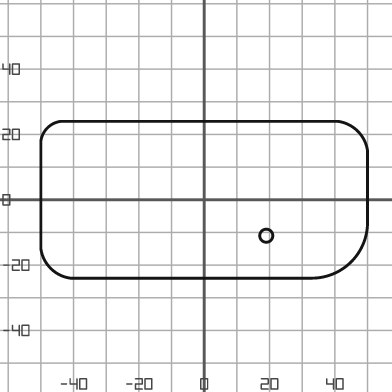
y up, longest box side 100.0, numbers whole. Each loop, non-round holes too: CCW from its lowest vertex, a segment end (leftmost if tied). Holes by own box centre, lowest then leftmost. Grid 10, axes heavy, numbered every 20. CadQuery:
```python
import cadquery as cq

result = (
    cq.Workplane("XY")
    .moveTo(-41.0, -24.0)
    .lineTo(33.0, -24.0)
    .threePointArc((45.0, -19.0), (50.0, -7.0))
    .lineTo(50.0, 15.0)
    .threePointArc((47.0, 21.0), (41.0, 24.0))
    .lineTo(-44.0, 24.0)
    .threePointArc((-48.0, 22.0), (-50.0, 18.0))
    .lineTo(-50.0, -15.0)
    .threePointArc((-47.0, -21.0), (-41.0, -24.0))
    .close()
    .moveTo(19.0, -11.0)
    .circle(2.0)
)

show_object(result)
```